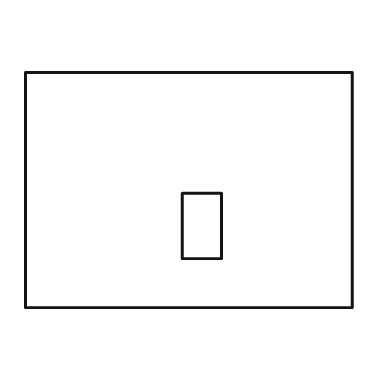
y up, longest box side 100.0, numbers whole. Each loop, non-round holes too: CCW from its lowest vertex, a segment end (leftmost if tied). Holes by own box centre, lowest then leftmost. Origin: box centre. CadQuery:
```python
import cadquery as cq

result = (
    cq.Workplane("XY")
    .moveTo(-50.0, -36.0)
    .lineTo(50.0, -36.0)
    .lineTo(50.0, 36.0)
    .lineTo(-50.0, 36.0)
    .close()
    .moveTo(-2.0, -21.0)
    .lineTo(10.0, -21.0)
    .lineTo(10.0, -1.0)
    .lineTo(-2.0, -1.0)
    .close()
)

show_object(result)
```